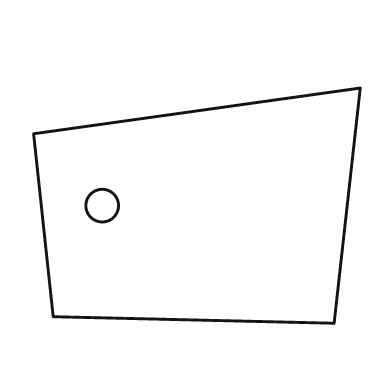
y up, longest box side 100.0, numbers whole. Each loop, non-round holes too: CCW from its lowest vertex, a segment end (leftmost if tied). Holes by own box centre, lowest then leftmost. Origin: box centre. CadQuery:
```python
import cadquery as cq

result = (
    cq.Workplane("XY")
    .moveTo(42.0, -36.0)
    .lineTo(50.0, 36.0)
    .lineTo(-50.0, 22.0)
    .lineTo(-44.0, -34.0)
    .close()
    .moveTo(-29.0, 0.0)
    .circle(5.0)
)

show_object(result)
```